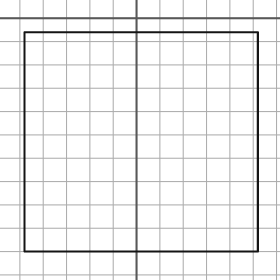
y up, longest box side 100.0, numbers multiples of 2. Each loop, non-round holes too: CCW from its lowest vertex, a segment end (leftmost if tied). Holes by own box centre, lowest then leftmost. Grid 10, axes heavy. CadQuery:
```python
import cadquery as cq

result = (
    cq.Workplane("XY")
    .moveTo(-48.0, -100.0)
    .lineTo(52.0, -100.0)
    .lineTo(52.0, -6.0)
    .lineTo(-48.0, -6.0)
    .close()
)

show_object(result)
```